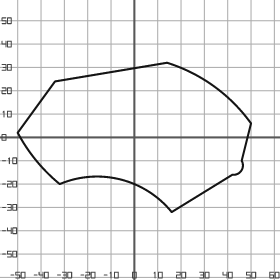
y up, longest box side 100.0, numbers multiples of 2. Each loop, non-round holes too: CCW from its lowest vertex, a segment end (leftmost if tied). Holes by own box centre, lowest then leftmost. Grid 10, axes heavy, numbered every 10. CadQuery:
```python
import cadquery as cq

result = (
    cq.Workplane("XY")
    .moveTo(16.0, -32.0)
    .lineTo(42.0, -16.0)
    .threePointArc((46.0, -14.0), (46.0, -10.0))
    .lineTo(50.0, 6.0)
    .threePointArc((34.0, 22.0), (14.0, 32.0))
    .lineTo(-34.0, 24.0)
    .lineTo(-50.0, 2.0)
    .threePointArc((-42.0, -10.0), (-32.0, -20.0))
    .threePointArc((-6.0, -18.0), (16.0, -32.0))
    .close()
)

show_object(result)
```